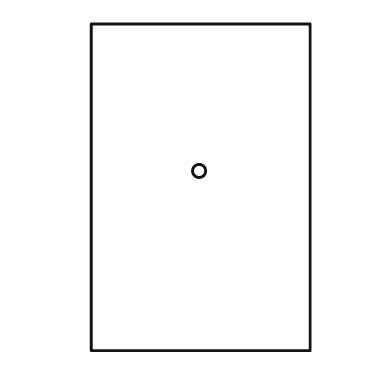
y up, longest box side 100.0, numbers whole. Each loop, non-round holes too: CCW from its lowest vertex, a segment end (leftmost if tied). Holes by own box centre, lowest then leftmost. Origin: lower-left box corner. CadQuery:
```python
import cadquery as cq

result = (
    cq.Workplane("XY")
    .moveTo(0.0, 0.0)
    .lineTo(67.0, 0.0)
    .lineTo(67.0, 100.0)
    .lineTo(0.0, 100.0)
    .close()
    .moveTo(33.0, 55.0)
    .circle(2.0)
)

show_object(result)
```